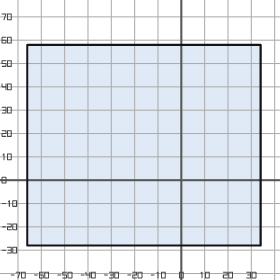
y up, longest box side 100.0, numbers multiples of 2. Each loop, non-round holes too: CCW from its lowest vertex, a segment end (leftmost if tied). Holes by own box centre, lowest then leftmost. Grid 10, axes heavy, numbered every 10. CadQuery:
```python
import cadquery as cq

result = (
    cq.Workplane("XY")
    .moveTo(-66.0, -28.0)
    .lineTo(34.0, -28.0)
    .lineTo(34.0, 58.0)
    .lineTo(-66.0, 58.0)
    .close()
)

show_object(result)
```